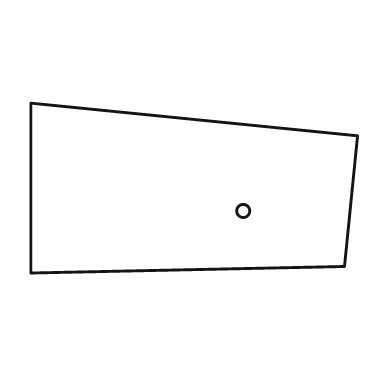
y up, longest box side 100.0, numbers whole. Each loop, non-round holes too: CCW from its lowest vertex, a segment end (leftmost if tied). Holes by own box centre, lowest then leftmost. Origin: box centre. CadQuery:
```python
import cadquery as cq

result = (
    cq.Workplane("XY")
    .moveTo(-50.0, -26.0)
    .lineTo(46.0, -24.0)
    .lineTo(50.0, 16.0)
    .lineTo(-50.0, 26.0)
    .close()
    .moveTo(15.0, -7.0)
    .circle(2.0)
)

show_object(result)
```